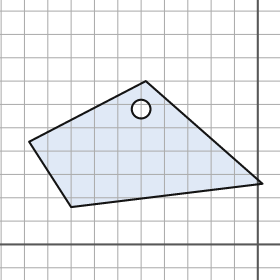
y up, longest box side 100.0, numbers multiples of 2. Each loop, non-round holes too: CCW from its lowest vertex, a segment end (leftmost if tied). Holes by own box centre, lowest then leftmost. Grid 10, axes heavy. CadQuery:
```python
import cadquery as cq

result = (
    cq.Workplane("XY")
    .moveTo(-80.0, 16.0)
    .lineTo(2.0, 26.0)
    .lineTo(-48.0, 70.0)
    .lineTo(-98.0, 44.0)
    .close()
    .moveTo(-50.0, 58.0)
    .circle(4.0)
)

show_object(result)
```